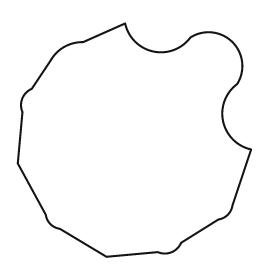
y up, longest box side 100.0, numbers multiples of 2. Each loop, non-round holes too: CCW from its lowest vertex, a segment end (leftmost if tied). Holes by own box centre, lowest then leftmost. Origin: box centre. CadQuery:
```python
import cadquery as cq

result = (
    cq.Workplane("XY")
    .moveTo(-12.0, -50.0)
    .lineTo(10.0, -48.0)
    .threePointArc((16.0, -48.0), (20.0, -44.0))
    .lineTo(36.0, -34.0)
    .threePointArc((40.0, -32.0), (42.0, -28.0))
    .lineTo(50.0, -4.0)
    .threePointArc((38.0, 8.0), (44.0, 24.0))
    .threePointArc((42.0, 42.0), (24.0, 44.0))
    .threePointArc((8.0, 38.0), (-4.0, 50.0))
    .lineTo(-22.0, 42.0)
    .threePointArc((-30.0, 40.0), (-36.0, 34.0))
    .lineTo(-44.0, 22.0)
    .threePointArc((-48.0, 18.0), (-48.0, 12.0))
    .lineTo(-50.0, -10.0)
    .lineTo(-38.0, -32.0)
    .threePointArc((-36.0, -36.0), (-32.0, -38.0))
    .close()
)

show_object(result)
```